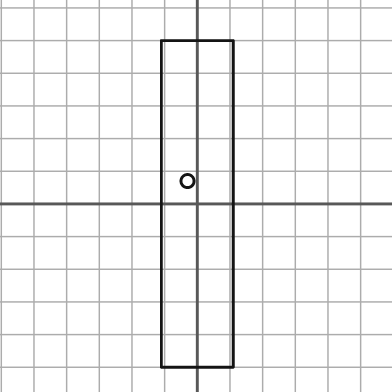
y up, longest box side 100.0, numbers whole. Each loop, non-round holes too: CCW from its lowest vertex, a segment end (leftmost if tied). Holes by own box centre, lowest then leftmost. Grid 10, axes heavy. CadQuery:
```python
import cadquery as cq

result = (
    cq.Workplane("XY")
    .moveTo(-11.0, -50.0)
    .lineTo(11.0, -50.0)
    .lineTo(11.0, 50.0)
    .lineTo(-11.0, 50.0)
    .close()
    .moveTo(-3.0, 7.0)
    .circle(2.0)
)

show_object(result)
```